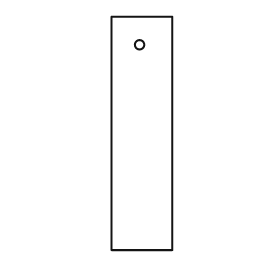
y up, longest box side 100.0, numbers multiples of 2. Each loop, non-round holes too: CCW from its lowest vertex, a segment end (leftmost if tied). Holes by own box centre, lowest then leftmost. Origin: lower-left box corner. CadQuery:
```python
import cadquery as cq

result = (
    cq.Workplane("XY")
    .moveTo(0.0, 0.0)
    .lineTo(26.0, 0.0)
    .lineTo(26.0, 100.0)
    .lineTo(0.0, 100.0)
    .close()
    .moveTo(12.0, 88.0)
    .circle(2.0)
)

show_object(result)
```